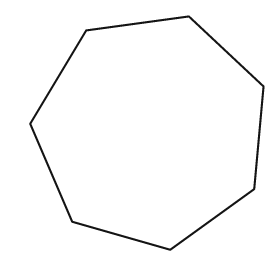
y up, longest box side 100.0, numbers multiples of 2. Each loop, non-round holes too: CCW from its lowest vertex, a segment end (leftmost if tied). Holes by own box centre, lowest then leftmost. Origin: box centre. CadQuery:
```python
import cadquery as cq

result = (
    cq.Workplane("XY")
    .moveTo(10.0, -50.0)
    .lineTo(46.0, -24.0)
    .lineTo(50.0, 20.0)
    .lineTo(18.0, 50.0)
    .lineTo(-26.0, 44.0)
    .lineTo(-50.0, 4.0)
    .lineTo(-32.0, -38.0)
    .close()
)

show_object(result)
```